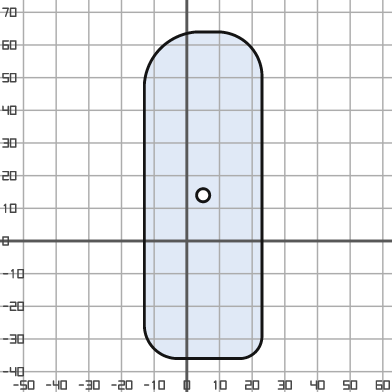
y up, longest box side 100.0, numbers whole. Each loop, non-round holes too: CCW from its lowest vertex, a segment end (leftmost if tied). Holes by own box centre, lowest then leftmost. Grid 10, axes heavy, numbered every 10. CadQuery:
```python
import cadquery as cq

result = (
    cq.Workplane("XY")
    .moveTo(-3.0, -36.0)
    .lineTo(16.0, -36.0)
    .threePointArc((21.0, -34.0), (23.0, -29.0))
    .lineTo(23.0, 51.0)
    .threePointArc((19.0, 60.0), (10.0, 64.0))
    .lineTo(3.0, 64.0)
    .threePointArc((-8.0, 59.0), (-13.0, 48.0))
    .lineTo(-13.0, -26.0)
    .threePointArc((-10.0, -33.0), (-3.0, -36.0))
    .close()
    .moveTo(5.0, 14.0)
    .circle(2.0)
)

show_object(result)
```